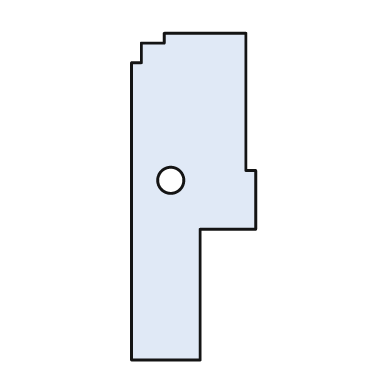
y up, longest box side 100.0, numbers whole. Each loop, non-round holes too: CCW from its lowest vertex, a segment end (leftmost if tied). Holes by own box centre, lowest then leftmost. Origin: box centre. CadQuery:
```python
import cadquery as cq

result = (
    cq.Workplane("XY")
    .moveTo(-19.0, -50.0)
    .lineTo(2.0, -50.0)
    .lineTo(2.0, -10.0)
    .lineTo(19.0, -10.0)
    .lineTo(19.0, 8.0)
    .lineTo(16.0, 8.0)
    .lineTo(16.0, 50.0)
    .lineTo(-9.0, 50.0)
    .lineTo(-9.0, 47.0)
    .lineTo(-16.0, 47.0)
    .lineTo(-16.0, 41.0)
    .lineTo(-19.0, 41.0)
    .close()
    .moveTo(-7.0, 5.0)
    .circle(4.0)
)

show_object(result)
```